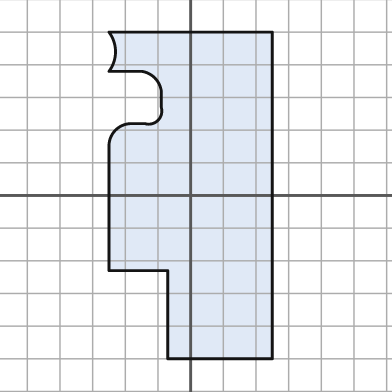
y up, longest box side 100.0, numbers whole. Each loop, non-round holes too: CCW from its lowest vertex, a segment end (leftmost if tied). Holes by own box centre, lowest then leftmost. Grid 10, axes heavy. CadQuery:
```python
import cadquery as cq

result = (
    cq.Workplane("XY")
    .moveTo(-7.0, -50.0)
    .lineTo(25.0, -50.0)
    .lineTo(25.0, 50.0)
    .lineTo(-25.0, 50.0)
    .threePointArc((-23.0, 44.0), (-25.0, 38.0))
    .lineTo(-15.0, 38.0)
    .threePointArc((-11.0, 36.0), (-9.0, 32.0))
    .lineTo(-9.0, 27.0)
    .threePointArc((-10.0, 23.0), (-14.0, 22.0))
    .lineTo(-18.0, 22.0)
    .threePointArc((-23.0, 20.0), (-25.0, 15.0))
    .lineTo(-25.0, -23.0)
    .lineTo(-7.0, -23.0)
    .close()
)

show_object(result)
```